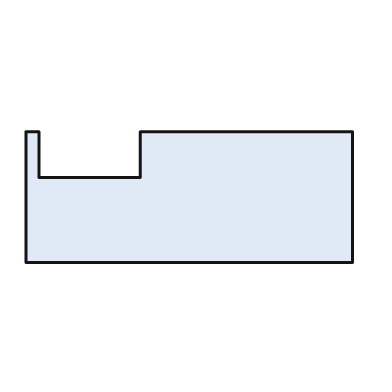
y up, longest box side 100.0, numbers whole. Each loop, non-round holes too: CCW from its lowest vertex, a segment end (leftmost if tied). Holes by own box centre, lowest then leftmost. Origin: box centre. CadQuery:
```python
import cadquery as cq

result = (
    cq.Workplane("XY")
    .moveTo(-50.0, -20.0)
    .lineTo(50.0, -20.0)
    .lineTo(50.0, 20.0)
    .lineTo(-15.0, 20.0)
    .lineTo(-15.0, 6.0)
    .lineTo(-46.0, 6.0)
    .lineTo(-46.0, 20.0)
    .lineTo(-50.0, 20.0)
    .close()
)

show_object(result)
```